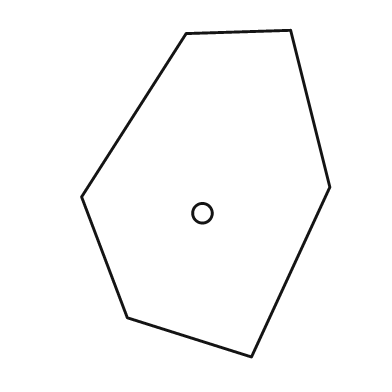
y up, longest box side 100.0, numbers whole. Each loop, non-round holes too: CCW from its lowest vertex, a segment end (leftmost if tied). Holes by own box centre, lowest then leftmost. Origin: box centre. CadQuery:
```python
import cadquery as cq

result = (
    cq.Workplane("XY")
    .moveTo(14.0, -50.0)
    .lineTo(38.0, 2.0)
    .lineTo(26.0, 50.0)
    .lineTo(-6.0, 49.0)
    .lineTo(-38.0, -1.0)
    .lineTo(-24.0, -38.0)
    .close()
    .moveTo(-1.0, -6.0)
    .circle(3.0)
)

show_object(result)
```